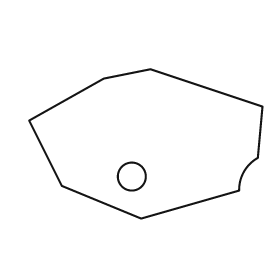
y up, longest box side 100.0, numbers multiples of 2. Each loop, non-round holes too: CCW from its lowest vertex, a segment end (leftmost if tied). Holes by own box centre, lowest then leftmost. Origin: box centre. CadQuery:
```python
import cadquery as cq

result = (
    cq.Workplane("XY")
    .moveTo(-2.0, -32.0)
    .lineTo(40.0, -20.0)
    .threePointArc((42.0, -12.0), (48.0, -6.0))
    .lineTo(50.0, 16.0)
    .lineTo(2.0, 32.0)
    .lineTo(-18.0, 28.0)
    .lineTo(-50.0, 10.0)
    .lineTo(-36.0, -18.0)
    .close()
    .moveTo(-6.0, -14.0)
    .circle(6.0)
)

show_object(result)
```